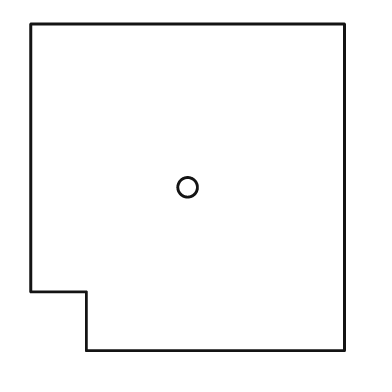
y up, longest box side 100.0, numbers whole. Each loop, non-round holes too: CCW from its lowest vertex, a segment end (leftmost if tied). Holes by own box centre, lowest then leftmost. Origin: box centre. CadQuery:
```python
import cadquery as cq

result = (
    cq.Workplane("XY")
    .moveTo(-31.0, -50.0)
    .lineTo(48.0, -50.0)
    .lineTo(48.0, 50.0)
    .lineTo(-48.0, 50.0)
    .lineTo(-48.0, -32.0)
    .lineTo(-31.0, -32.0)
    .close()
    .moveTo(0.0, 0.0)
    .circle(3.0)
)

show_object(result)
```